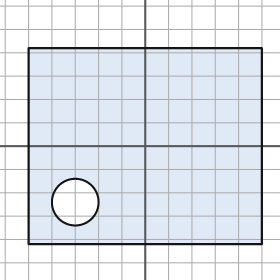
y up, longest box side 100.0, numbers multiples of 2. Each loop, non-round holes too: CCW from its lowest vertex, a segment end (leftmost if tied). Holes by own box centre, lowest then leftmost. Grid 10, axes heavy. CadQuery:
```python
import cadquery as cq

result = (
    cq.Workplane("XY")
    .moveTo(-50.0, -42.0)
    .lineTo(50.0, -42.0)
    .lineTo(50.0, 42.0)
    .lineTo(-50.0, 42.0)
    .close()
    .moveTo(-30.0, -24.0)
    .circle(10.0)
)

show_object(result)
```